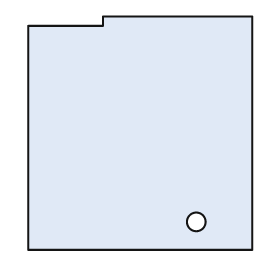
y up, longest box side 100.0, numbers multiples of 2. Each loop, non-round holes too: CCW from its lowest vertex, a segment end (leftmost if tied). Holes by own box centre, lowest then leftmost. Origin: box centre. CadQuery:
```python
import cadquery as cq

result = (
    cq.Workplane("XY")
    .moveTo(-48.0, -50.0)
    .lineTo(48.0, -50.0)
    .lineTo(48.0, 50.0)
    .lineTo(-16.0, 50.0)
    .lineTo(-16.0, 46.0)
    .lineTo(-48.0, 46.0)
    .close()
    .moveTo(24.0, -38.0)
    .circle(4.0)
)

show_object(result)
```